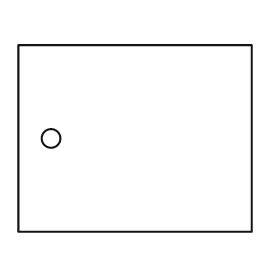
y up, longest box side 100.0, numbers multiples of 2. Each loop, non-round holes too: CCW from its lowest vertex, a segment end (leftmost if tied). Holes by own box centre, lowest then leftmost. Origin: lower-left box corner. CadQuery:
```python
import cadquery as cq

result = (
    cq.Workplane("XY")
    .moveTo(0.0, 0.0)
    .lineTo(100.0, 0.0)
    .lineTo(100.0, 80.0)
    .lineTo(0.0, 80.0)
    .close()
    .moveTo(14.0, 40.0)
    .circle(4.0)
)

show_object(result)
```